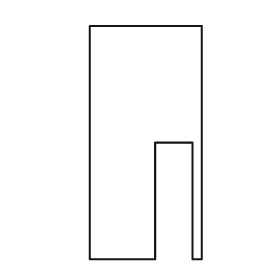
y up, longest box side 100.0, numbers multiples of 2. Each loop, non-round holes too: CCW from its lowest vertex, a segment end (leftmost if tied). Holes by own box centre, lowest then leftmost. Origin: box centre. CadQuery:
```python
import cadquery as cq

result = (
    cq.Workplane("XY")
    .moveTo(-24.0, -50.0)
    .lineTo(4.0, -50.0)
    .lineTo(4.0, 0.0)
    .lineTo(20.0, 0.0)
    .lineTo(20.0, -50.0)
    .lineTo(24.0, -50.0)
    .lineTo(24.0, 50.0)
    .lineTo(-24.0, 50.0)
    .close()
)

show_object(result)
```